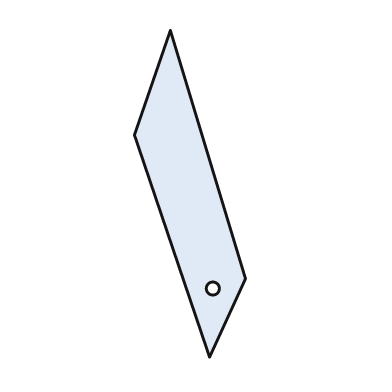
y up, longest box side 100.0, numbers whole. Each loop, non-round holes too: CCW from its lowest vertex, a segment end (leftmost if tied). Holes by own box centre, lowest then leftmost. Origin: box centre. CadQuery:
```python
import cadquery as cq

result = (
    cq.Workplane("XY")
    .moveTo(6.0, -50.0)
    .lineTo(17.0, -26.0)
    .lineTo(-6.0, 50.0)
    .lineTo(-17.0, 18.0)
    .close()
    .moveTo(7.0, -29.0)
    .circle(2.0)
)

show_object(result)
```